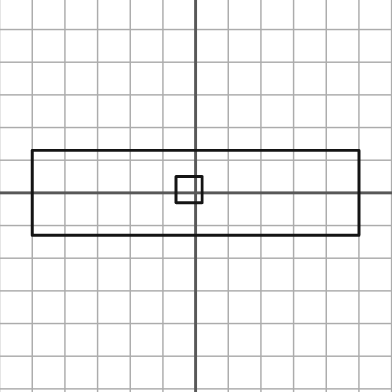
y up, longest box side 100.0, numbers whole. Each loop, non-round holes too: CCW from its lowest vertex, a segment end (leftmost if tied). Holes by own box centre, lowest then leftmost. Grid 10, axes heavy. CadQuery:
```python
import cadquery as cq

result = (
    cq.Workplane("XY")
    .moveTo(-50.0, -13.0)
    .lineTo(50.0, -13.0)
    .lineTo(50.0, 13.0)
    .lineTo(-50.0, 13.0)
    .close()
    .moveTo(-6.0, -3.0)
    .lineTo(2.0, -3.0)
    .lineTo(2.0, 5.0)
    .lineTo(-6.0, 5.0)
    .close()
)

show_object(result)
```